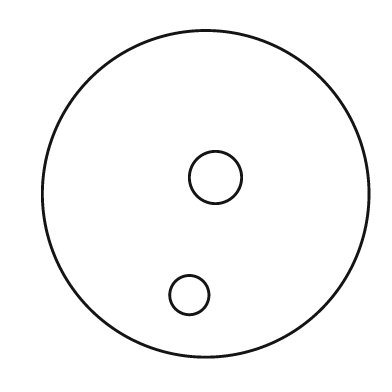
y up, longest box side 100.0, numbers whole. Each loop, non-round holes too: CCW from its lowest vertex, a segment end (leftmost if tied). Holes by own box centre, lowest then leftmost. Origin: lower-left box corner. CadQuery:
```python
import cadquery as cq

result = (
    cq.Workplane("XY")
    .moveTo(50.0, 50.0)
    .circle(50.0)
    .moveTo(45.0, 19.0)
    .circle(6.0)
    .moveTo(53.0, 55.0)
    .circle(8.0)
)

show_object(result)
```